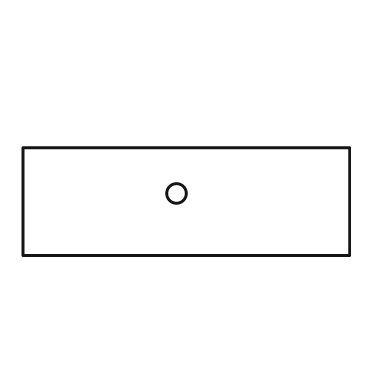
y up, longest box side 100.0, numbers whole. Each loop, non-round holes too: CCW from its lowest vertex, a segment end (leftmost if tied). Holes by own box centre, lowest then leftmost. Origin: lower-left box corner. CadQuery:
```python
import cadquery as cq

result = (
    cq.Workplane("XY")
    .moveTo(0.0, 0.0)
    .lineTo(100.0, 0.0)
    .lineTo(100.0, 33.0)
    .lineTo(0.0, 33.0)
    .close()
    .moveTo(47.0, 19.0)
    .circle(3.0)
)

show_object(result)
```